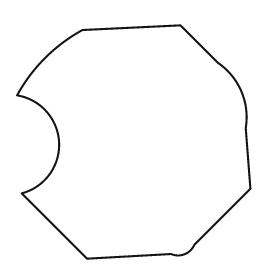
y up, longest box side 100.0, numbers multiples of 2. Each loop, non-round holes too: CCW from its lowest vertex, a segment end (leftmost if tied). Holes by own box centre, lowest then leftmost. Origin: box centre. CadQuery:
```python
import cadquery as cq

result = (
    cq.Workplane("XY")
    .moveTo(-20.0, -50.0)
    .lineTo(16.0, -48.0)
    .threePointArc((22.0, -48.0), (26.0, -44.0))
    .lineTo(50.0, -20.0)
    .lineTo(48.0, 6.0)
    .threePointArc((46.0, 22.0), (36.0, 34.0))
    .lineTo(20.0, 50.0)
    .lineTo(-22.0, 48.0)
    .threePointArc((-38.0, 36.0), (-50.0, 20.0))
    .threePointArc((-32.0, 0.0), (-48.0, -22.0))
    .close()
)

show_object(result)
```